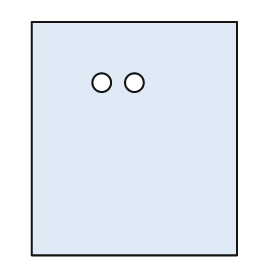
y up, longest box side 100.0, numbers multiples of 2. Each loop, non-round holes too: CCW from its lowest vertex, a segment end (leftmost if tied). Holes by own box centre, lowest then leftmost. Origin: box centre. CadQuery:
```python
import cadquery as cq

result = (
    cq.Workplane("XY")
    .moveTo(-44.0, -50.0)
    .lineTo(44.0, -50.0)
    .lineTo(44.0, 50.0)
    .lineTo(-44.0, 50.0)
    .close()
    .moveTo(-14.0, 24.0)
    .circle(4.0)
    .moveTo(0.0, 24.0)
    .circle(4.0)
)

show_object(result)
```